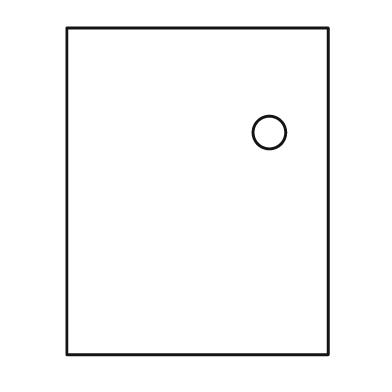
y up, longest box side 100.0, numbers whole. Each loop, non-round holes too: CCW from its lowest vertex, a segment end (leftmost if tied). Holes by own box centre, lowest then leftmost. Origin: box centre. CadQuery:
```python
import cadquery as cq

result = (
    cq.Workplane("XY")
    .moveTo(-40.0, -50.0)
    .lineTo(40.0, -50.0)
    .lineTo(40.0, 50.0)
    .lineTo(-40.0, 50.0)
    .close()
    .moveTo(22.0, 18.0)
    .circle(5.0)
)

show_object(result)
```